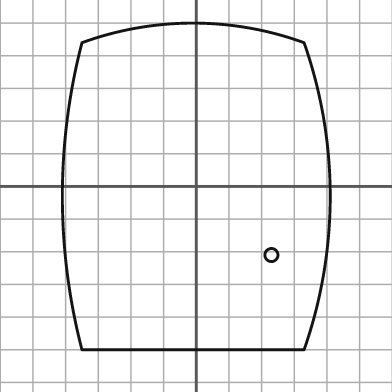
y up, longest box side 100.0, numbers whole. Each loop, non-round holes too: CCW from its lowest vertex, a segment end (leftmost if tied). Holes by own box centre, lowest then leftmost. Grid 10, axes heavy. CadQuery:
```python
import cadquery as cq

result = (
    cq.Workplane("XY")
    .moveTo(-35.0, -50.0)
    .lineTo(33.0, -50.0)
    .threePointArc((41.0, -3.0), (33.0, 44.0))
    .threePointArc((-1.0, 50.0), (-35.0, 44.0))
    .threePointArc((-41.0, -3.0), (-35.0, -50.0))
    .close()
    .moveTo(23.0, -21.0)
    .circle(2.0)
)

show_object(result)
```